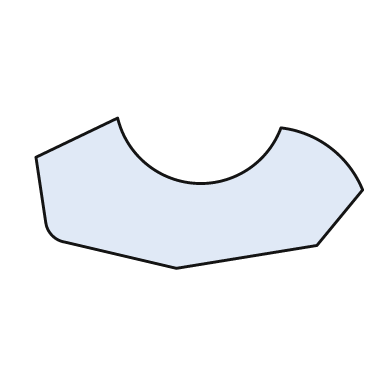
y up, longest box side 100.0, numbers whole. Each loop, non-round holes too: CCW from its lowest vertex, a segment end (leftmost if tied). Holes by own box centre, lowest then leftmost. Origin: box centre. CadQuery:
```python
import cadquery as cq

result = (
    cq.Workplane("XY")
    .moveTo(-7.0, -23.0)
    .lineTo(36.0, -16.0)
    .lineTo(50.0, 1.0)
    .threePointArc((40.0, 14.0), (25.0, 20.0))
    .threePointArc((-1.0, 3.0), (-25.0, 23.0))
    .lineTo(-50.0, 11.0)
    .lineTo(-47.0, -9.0)
    .threePointArc((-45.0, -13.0), (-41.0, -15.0))
    .close()
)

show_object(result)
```